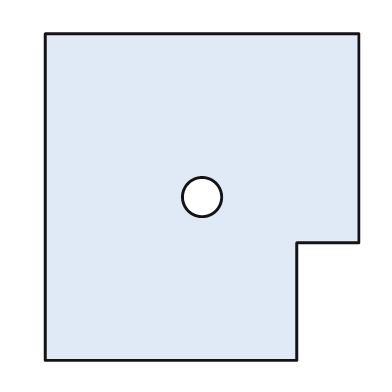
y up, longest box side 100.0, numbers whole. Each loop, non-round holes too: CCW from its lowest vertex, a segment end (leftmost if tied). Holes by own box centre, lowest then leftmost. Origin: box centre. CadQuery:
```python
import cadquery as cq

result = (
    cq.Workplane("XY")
    .moveTo(-48.0, -50.0)
    .lineTo(29.0, -50.0)
    .lineTo(29.0, -14.0)
    .lineTo(48.0, -14.0)
    .lineTo(48.0, 50.0)
    .lineTo(-48.0, 50.0)
    .close()
    .moveTo(0.0, 0.0)
    .circle(6.0)
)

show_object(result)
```